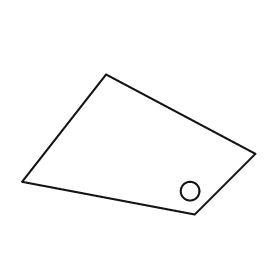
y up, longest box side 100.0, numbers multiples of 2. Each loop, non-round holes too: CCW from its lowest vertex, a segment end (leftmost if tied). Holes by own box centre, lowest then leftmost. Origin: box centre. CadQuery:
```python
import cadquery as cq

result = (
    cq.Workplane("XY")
    .moveTo(24.0, -30.0)
    .lineTo(50.0, -4.0)
    .lineTo(-14.0, 30.0)
    .lineTo(-50.0, -16.0)
    .close()
    .moveTo(22.0, -20.0)
    .circle(4.0)
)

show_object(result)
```